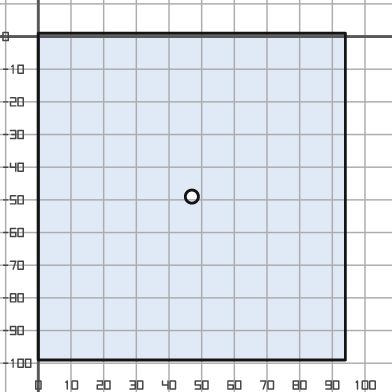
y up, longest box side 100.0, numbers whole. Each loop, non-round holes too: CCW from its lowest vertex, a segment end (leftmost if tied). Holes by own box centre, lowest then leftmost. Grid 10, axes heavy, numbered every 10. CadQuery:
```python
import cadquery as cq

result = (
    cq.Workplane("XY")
    .moveTo(0.0, -99.0)
    .lineTo(94.0, -99.0)
    .lineTo(94.0, 1.0)
    .lineTo(0.0, 1.0)
    .close()
    .moveTo(47.0, -49.0)
    .circle(2.0)
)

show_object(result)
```